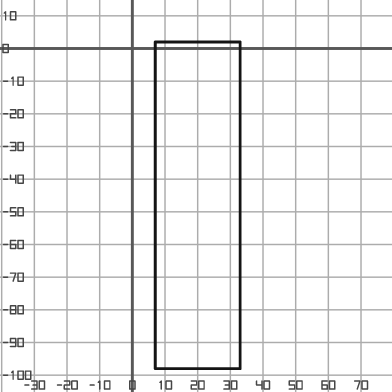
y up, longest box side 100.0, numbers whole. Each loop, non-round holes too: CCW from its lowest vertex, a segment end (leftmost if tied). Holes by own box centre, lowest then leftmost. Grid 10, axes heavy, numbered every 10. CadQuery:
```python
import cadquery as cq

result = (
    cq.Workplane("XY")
    .moveTo(7.0, -98.0)
    .lineTo(33.0, -98.0)
    .lineTo(33.0, 2.0)
    .lineTo(7.0, 2.0)
    .close()
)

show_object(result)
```